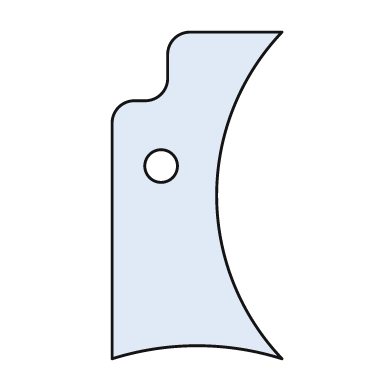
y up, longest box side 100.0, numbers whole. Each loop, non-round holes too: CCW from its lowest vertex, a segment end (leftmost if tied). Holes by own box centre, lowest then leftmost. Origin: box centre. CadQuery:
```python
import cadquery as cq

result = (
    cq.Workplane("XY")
    .moveTo(-26.0, -50.0)
    .threePointArc((0.0, -46.0), (26.0, -50.0))
    .threePointArc((6.0, 0.0), (26.0, 50.0))
    .lineTo(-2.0, 50.0)
    .threePointArc((-7.0, 48.0), (-9.0, 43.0))
    .lineTo(-9.0, 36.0)
    .threePointArc((-11.0, 31.0), (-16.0, 29.0))
    .lineTo(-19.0, 29.0)
    .threePointArc((-24.0, 27.0), (-26.0, 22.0))
    .close()
    .moveTo(-11.0, 9.0)
    .circle(5.0)
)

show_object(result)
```